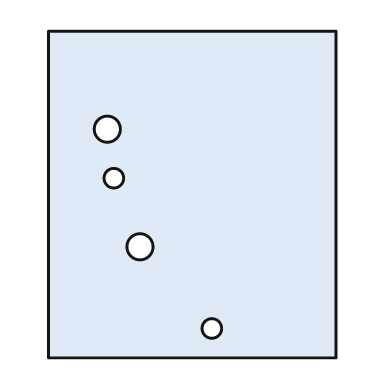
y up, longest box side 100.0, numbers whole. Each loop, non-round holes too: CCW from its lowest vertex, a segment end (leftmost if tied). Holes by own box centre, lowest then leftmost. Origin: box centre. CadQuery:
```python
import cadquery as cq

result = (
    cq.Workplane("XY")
    .moveTo(-44.0, -50.0)
    .lineTo(44.0, -50.0)
    .lineTo(44.0, 50.0)
    .lineTo(-44.0, 50.0)
    .close()
    .moveTo(6.0, -41.0)
    .circle(3.0)
    .moveTo(-16.0, -16.0)
    .circle(4.0)
    .moveTo(-24.0, 5.0)
    .circle(3.0)
    .moveTo(-26.0, 20.0)
    .circle(4.0)
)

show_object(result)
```